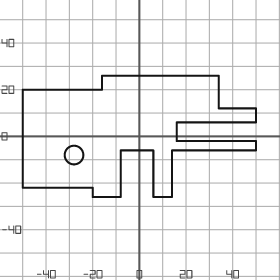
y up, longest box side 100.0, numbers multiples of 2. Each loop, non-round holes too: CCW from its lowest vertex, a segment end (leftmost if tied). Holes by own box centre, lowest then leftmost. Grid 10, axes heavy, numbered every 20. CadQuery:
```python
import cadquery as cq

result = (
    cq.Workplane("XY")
    .moveTo(-20.0, -26.0)
    .lineTo(-8.0, -26.0)
    .lineTo(-8.0, -6.0)
    .lineTo(6.0, -6.0)
    .lineTo(6.0, -26.0)
    .lineTo(14.0, -26.0)
    .lineTo(14.0, -6.0)
    .lineTo(50.0, -6.0)
    .lineTo(50.0, -2.0)
    .lineTo(16.0, -2.0)
    .lineTo(16.0, 6.0)
    .lineTo(50.0, 6.0)
    .lineTo(50.0, 12.0)
    .lineTo(34.0, 12.0)
    .lineTo(34.0, 26.0)
    .lineTo(-16.0, 26.0)
    .lineTo(-16.0, 20.0)
    .lineTo(-50.0, 20.0)
    .lineTo(-50.0, -22.0)
    .lineTo(-20.0, -22.0)
    .close()
    .moveTo(-28.0, -8.0)
    .circle(4.0)
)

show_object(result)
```